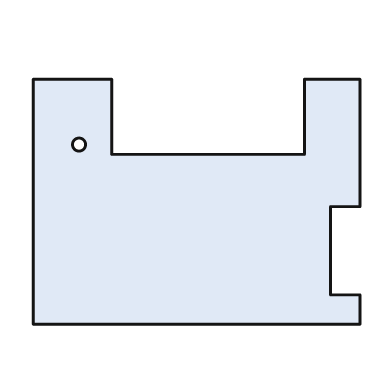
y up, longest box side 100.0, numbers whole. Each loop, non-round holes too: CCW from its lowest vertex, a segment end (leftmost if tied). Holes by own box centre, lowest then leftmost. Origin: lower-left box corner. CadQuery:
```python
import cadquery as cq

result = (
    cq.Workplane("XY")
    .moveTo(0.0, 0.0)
    .lineTo(100.0, 0.0)
    .lineTo(100.0, 9.0)
    .lineTo(91.0, 9.0)
    .lineTo(91.0, 36.0)
    .lineTo(100.0, 36.0)
    .lineTo(100.0, 75.0)
    .lineTo(83.0, 75.0)
    .lineTo(83.0, 52.0)
    .lineTo(24.0, 52.0)
    .lineTo(24.0, 75.0)
    .lineTo(0.0, 75.0)
    .close()
    .moveTo(14.0, 55.0)
    .circle(2.0)
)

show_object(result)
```